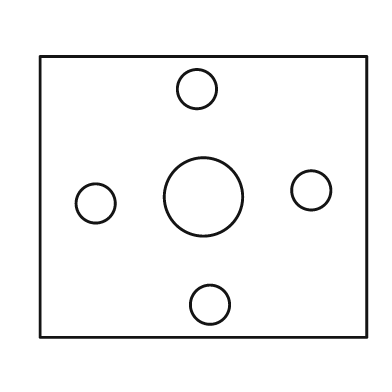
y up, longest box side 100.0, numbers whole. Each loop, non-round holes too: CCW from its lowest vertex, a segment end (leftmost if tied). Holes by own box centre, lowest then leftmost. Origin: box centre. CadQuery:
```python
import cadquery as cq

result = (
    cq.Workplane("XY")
    .moveTo(-50.0, -43.0)
    .lineTo(50.0, -43.0)
    .lineTo(50.0, 43.0)
    .lineTo(-50.0, 43.0)
    .close()
    .moveTo(2.0, -33.0)
    .circle(6.0)
    .moveTo(-33.0, -2.0)
    .circle(6.0)
    .moveTo(0.0, 0.0)
    .circle(12.0)
    .moveTo(33.0, 2.0)
    .circle(6.0)
    .moveTo(-2.0, 33.0)
    .circle(6.0)
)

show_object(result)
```